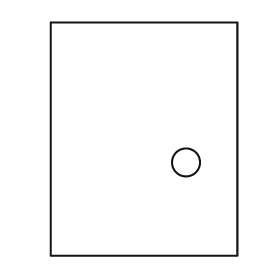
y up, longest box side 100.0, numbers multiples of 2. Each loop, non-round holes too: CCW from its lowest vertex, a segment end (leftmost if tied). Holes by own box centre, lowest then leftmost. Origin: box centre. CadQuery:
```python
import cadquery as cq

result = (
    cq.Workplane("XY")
    .moveTo(-40.0, -50.0)
    .lineTo(40.0, -50.0)
    .lineTo(40.0, 50.0)
    .lineTo(-40.0, 50.0)
    .close()
    .moveTo(18.0, -10.0)
    .circle(6.0)
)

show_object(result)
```